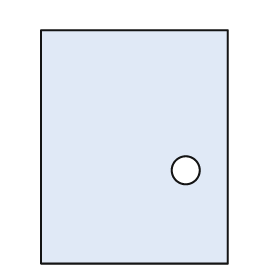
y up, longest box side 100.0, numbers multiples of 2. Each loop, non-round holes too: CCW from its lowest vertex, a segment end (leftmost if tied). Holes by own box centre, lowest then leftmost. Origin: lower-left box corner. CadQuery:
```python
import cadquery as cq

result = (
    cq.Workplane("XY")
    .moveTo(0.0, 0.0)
    .lineTo(80.0, 0.0)
    .lineTo(80.0, 100.0)
    .lineTo(0.0, 100.0)
    .close()
    .moveTo(62.0, 40.0)
    .circle(6.0)
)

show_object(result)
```